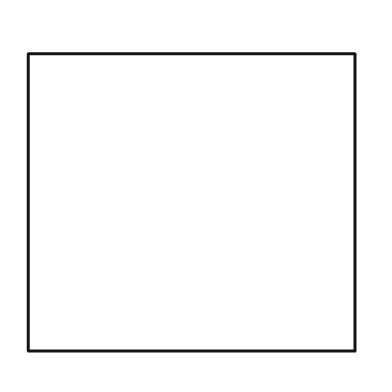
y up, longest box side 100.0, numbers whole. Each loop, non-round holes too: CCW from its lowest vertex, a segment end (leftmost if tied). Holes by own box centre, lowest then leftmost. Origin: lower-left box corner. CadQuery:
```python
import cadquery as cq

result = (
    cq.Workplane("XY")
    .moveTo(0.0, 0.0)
    .lineTo(100.0, 0.0)
    .lineTo(100.0, 91.0)
    .lineTo(0.0, 91.0)
    .close()
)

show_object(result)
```